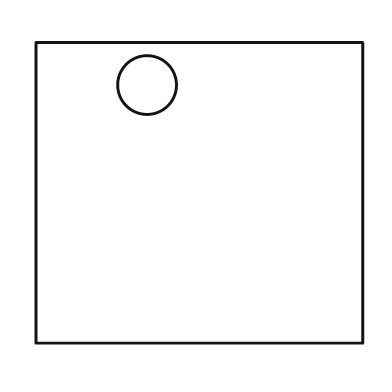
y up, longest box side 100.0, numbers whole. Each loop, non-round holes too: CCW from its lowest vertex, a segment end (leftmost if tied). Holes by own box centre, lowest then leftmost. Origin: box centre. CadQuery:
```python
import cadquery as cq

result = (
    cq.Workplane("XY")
    .moveTo(-50.0, -46.0)
    .lineTo(50.0, -46.0)
    .lineTo(50.0, 46.0)
    .lineTo(-50.0, 46.0)
    .close()
    .moveTo(-16.0, 33.0)
    .circle(9.0)
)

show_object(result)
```